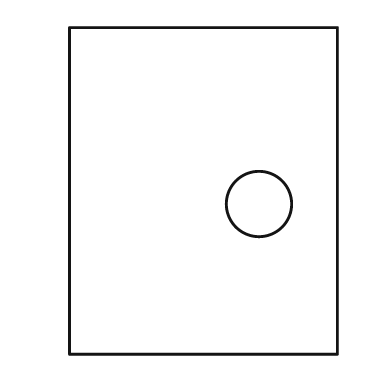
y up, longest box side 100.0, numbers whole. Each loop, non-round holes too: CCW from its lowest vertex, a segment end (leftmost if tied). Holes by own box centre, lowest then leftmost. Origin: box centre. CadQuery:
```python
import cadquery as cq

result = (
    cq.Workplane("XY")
    .moveTo(-41.0, -50.0)
    .lineTo(41.0, -50.0)
    .lineTo(41.0, 50.0)
    .lineTo(-41.0, 50.0)
    .close()
    .moveTo(17.0, -4.0)
    .circle(10.0)
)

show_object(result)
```